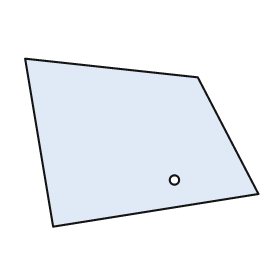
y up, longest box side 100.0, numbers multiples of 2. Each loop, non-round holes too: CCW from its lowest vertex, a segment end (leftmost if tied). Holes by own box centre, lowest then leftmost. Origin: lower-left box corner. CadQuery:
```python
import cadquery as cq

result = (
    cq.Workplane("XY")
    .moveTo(12.0, 0.0)
    .lineTo(100.0, 14.0)
    .lineTo(74.0, 64.0)
    .lineTo(0.0, 72.0)
    .close()
    .moveTo(64.0, 20.0)
    .circle(2.0)
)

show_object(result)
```